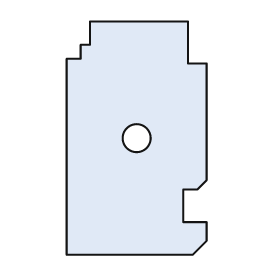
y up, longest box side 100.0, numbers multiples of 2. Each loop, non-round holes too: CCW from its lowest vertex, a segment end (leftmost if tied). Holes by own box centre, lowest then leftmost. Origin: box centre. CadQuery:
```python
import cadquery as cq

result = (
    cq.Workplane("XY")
    .moveTo(-30.0, -50.0)
    .lineTo(24.0, -50.0)
    .lineTo(30.0, -44.0)
    .lineTo(30.0, -36.0)
    .lineTo(20.0, -36.0)
    .lineTo(20.0, -22.0)
    .lineTo(26.0, -22.0)
    .lineTo(30.0, -18.0)
    .lineTo(30.0, 32.0)
    .lineTo(22.0, 32.0)
    .lineTo(22.0, 50.0)
    .lineTo(-20.0, 50.0)
    .lineTo(-20.0, 40.0)
    .lineTo(-24.0, 40.0)
    .lineTo(-24.0, 34.0)
    .lineTo(-30.0, 34.0)
    .close()
    .moveTo(0.0, 0.0)
    .circle(6.0)
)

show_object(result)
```